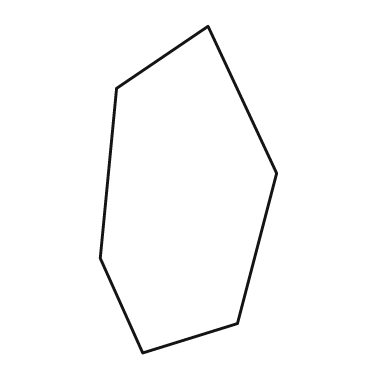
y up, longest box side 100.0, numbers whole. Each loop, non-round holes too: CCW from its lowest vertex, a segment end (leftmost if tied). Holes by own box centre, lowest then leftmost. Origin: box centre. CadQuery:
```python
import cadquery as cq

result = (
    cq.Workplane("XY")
    .moveTo(-14.0, -50.0)
    .lineTo(15.0, -41.0)
    .lineTo(27.0, 5.0)
    .lineTo(6.0, 50.0)
    .lineTo(-22.0, 31.0)
    .lineTo(-27.0, -21.0)
    .close()
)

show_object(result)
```